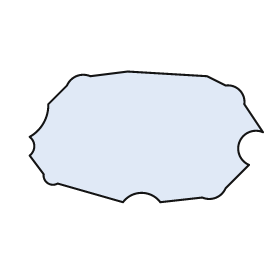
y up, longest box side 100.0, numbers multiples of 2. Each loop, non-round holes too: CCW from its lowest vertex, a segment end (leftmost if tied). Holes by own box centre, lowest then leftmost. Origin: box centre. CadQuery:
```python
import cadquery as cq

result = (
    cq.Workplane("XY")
    .moveTo(-10.0, -28.0)
    .threePointArc((-2.0, -24.0), (6.0, -28.0))
    .lineTo(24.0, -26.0)
    .threePointArc((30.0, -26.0), (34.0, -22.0))
    .lineTo(44.0, -12.0)
    .threePointArc((40.0, -2.0), (50.0, 2.0))
    .lineTo(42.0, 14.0)
    .threePointArc((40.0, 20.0), (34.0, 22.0))
    .lineTo(26.0, 26.0)
    .lineTo(-8.0, 28.0)
    .lineTo(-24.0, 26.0)
    .threePointArc((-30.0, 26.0), (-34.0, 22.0))
    .lineTo(-42.0, 14.0)
    .threePointArc((-44.0, 6.0), (-50.0, 0.0))
    .threePointArc((-48.0, -4.0), (-50.0, -8.0))
    .lineTo(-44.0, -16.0)
    .threePointArc((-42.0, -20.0), (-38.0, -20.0))
    .close()
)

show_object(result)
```